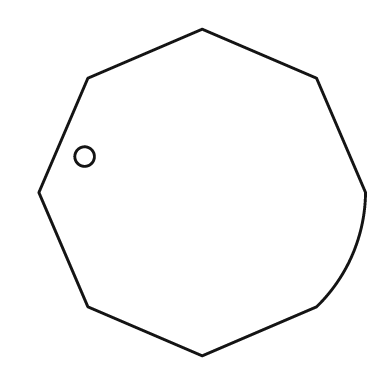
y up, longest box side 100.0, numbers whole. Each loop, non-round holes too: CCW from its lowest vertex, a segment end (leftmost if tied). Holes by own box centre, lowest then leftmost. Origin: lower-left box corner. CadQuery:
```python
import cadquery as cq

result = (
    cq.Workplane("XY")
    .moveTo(50.0, 0.0)
    .lineTo(85.0, 15.0)
    .threePointArc((96.0, 31.0), (100.0, 50.0))
    .lineTo(85.0, 85.0)
    .lineTo(50.0, 100.0)
    .lineTo(15.0, 85.0)
    .lineTo(0.0, 50.0)
    .lineTo(15.0, 15.0)
    .close()
    .moveTo(14.0, 61.0)
    .circle(3.0)
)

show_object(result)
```